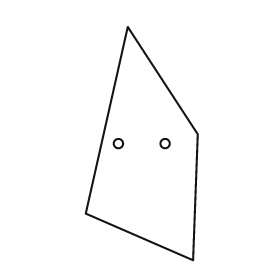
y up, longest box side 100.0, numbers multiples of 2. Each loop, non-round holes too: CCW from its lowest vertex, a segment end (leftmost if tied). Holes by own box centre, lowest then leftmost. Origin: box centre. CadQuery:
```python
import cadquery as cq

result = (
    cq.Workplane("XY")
    .moveTo(22.0, -50.0)
    .lineTo(24.0, 4.0)
    .lineTo(-6.0, 50.0)
    .lineTo(-24.0, -30.0)
    .close()
    .moveTo(-10.0, 0.0)
    .circle(2.0)
    .moveTo(10.0, 0.0)
    .circle(2.0)
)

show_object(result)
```